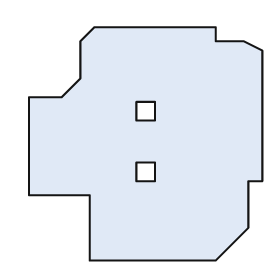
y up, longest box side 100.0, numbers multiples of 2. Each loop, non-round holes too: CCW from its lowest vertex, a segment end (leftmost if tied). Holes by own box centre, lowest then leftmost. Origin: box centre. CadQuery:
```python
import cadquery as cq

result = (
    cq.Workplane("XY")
    .moveTo(-24.0, -50.0)
    .lineTo(30.0, -50.0)
    .lineTo(44.0, -36.0)
    .lineTo(44.0, -16.0)
    .lineTo(50.0, -16.0)
    .lineTo(50.0, 40.0)
    .lineTo(42.0, 44.0)
    .lineTo(30.0, 44.0)
    .lineTo(30.0, 50.0)
    .lineTo(-22.0, 50.0)
    .lineTo(-28.0, 44.0)
    .lineTo(-28.0, 28.0)
    .lineTo(-36.0, 20.0)
    .lineTo(-50.0, 20.0)
    .lineTo(-50.0, -22.0)
    .lineTo(-24.0, -22.0)
    .close()
    .moveTo(-4.0, -16.0)
    .lineTo(4.0, -16.0)
    .lineTo(4.0, -8.0)
    .lineTo(-4.0, -8.0)
    .close()
    .moveTo(-4.0, 10.0)
    .lineTo(4.0, 10.0)
    .lineTo(4.0, 18.0)
    .lineTo(-4.0, 18.0)
    .close()
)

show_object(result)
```